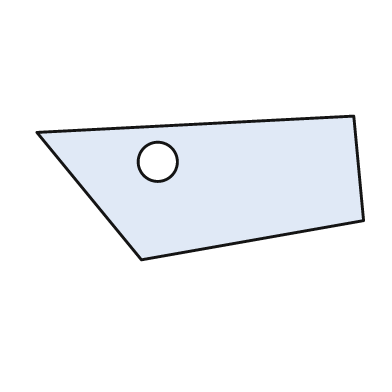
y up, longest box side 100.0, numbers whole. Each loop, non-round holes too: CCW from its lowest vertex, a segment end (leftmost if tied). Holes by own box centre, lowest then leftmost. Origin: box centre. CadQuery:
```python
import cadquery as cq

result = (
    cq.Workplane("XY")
    .moveTo(-18.0, -22.0)
    .lineTo(50.0, -10.0)
    .lineTo(47.0, 22.0)
    .lineTo(-50.0, 17.0)
    .close()
    .moveTo(-13.0, 8.0)
    .circle(6.0)
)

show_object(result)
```